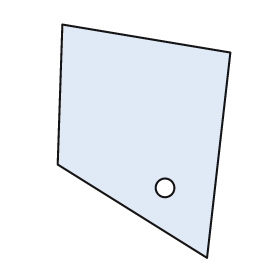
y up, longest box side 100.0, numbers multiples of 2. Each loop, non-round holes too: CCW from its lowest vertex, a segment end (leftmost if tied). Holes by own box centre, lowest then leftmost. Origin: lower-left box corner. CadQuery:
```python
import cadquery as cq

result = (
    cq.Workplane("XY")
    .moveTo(64.0, 0.0)
    .lineTo(74.0, 88.0)
    .lineTo(2.0, 100.0)
    .lineTo(0.0, 40.0)
    .close()
    .moveTo(46.0, 30.0)
    .circle(4.0)
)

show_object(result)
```